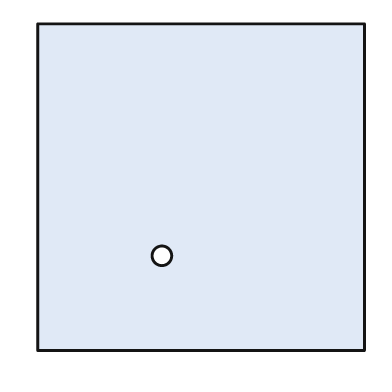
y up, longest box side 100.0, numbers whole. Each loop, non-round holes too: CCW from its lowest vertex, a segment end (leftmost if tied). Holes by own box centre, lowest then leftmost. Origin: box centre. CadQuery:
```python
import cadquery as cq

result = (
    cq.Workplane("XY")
    .moveTo(-50.0, -50.0)
    .lineTo(50.0, -50.0)
    .lineTo(50.0, 50.0)
    .lineTo(-50.0, 50.0)
    .close()
    .moveTo(-12.0, -21.0)
    .circle(3.0)
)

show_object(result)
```